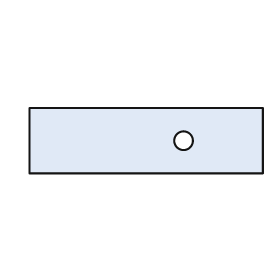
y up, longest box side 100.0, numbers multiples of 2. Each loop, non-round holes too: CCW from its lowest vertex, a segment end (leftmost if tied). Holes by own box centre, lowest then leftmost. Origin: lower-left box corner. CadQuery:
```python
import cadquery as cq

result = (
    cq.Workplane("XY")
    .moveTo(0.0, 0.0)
    .lineTo(100.0, 0.0)
    .lineTo(100.0, 28.0)
    .lineTo(0.0, 28.0)
    .close()
    .moveTo(66.0, 14.0)
    .circle(4.0)
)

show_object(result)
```